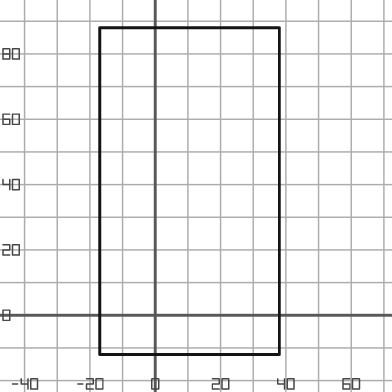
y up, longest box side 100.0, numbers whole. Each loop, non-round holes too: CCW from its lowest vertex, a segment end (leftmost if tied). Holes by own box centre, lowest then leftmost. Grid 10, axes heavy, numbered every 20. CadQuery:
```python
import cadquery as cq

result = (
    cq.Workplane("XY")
    .moveTo(-17.0, -12.0)
    .lineTo(38.0, -12.0)
    .lineTo(38.0, 88.0)
    .lineTo(-17.0, 88.0)
    .close()
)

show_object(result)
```